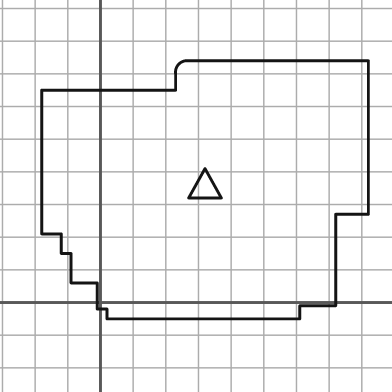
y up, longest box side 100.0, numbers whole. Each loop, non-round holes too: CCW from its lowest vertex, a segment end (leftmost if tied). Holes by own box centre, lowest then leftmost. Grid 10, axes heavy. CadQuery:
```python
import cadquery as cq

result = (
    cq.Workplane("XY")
    .moveTo(2.0, -5.0)
    .lineTo(61.0, -5.0)
    .lineTo(61.0, -1.0)
    .lineTo(72.0, -1.0)
    .lineTo(72.0, 27.0)
    .lineTo(82.0, 27.0)
    .lineTo(82.0, 74.0)
    .lineTo(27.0, 74.0)
    .threePointArc((24.0, 73.0), (23.0, 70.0))
    .lineTo(23.0, 65.0)
    .lineTo(-18.0, 65.0)
    .lineTo(-18.0, 21.0)
    .lineTo(-12.0, 21.0)
    .lineTo(-12.0, 15.0)
    .lineTo(-9.0, 15.0)
    .lineTo(-9.0, 6.0)
    .lineTo(-1.0, 6.0)
    .lineTo(-1.0, -2.0)
    .lineTo(2.0, -2.0)
    .close()
    .moveTo(27.0, 32.0)
    .lineTo(37.0, 32.0)
    .lineTo(32.0, 41.0)
    .close()
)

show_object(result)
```